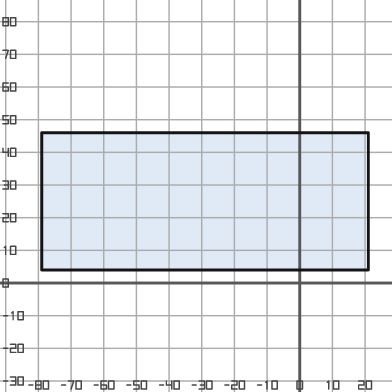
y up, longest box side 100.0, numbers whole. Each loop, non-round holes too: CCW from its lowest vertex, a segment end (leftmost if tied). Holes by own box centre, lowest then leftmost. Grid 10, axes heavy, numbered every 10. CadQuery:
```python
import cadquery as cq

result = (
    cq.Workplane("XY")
    .moveTo(-79.0, 4.0)
    .lineTo(21.0, 4.0)
    .lineTo(21.0, 46.0)
    .lineTo(-79.0, 46.0)
    .close()
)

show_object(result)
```